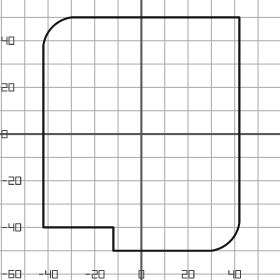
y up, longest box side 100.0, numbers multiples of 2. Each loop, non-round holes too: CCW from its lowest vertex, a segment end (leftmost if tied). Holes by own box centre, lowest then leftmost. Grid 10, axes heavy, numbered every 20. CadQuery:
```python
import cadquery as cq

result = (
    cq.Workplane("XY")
    .moveTo(-12.0, -50.0)
    .lineTo(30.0, -50.0)
    .threePointArc((38.0, -46.0), (42.0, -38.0))
    .lineTo(42.0, 50.0)
    .lineTo(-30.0, 50.0)
    .threePointArc((-38.0, 46.0), (-42.0, 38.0))
    .lineTo(-42.0, -40.0)
    .lineTo(-12.0, -40.0)
    .close()
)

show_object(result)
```